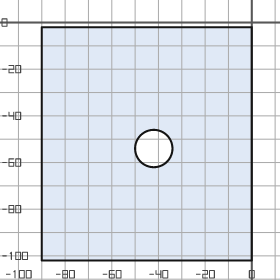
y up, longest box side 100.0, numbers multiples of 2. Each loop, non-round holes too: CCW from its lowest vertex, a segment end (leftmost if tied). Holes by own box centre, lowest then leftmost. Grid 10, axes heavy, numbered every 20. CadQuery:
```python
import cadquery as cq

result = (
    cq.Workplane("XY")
    .moveTo(-90.0, -102.0)
    .lineTo(0.0, -102.0)
    .lineTo(0.0, -2.0)
    .lineTo(-90.0, -2.0)
    .close()
    .moveTo(-42.0, -54.0)
    .circle(8.0)
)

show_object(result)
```